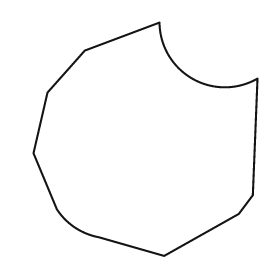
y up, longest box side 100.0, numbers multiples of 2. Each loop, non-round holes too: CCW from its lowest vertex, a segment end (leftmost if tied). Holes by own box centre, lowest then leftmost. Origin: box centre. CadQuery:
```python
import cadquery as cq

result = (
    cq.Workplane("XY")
    .moveTo(8.0, -50.0)
    .lineTo(40.0, -32.0)
    .lineTo(46.0, -24.0)
    .lineTo(48.0, 26.0)
    .threePointArc((20.0, 26.0), (6.0, 50.0))
    .lineTo(-26.0, 38.0)
    .lineTo(-42.0, 20.0)
    .lineTo(-48.0, -6.0)
    .lineTo(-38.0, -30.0)
    .threePointArc((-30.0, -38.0), (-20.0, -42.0))
    .close()
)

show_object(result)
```